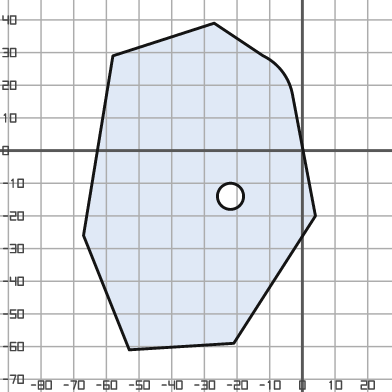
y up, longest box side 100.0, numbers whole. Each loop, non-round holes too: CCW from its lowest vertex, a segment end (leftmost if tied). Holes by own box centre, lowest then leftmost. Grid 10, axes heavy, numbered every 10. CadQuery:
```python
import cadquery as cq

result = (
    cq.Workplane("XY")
    .moveTo(-53.0, -61.0)
    .lineTo(-21.0, -59.0)
    .lineTo(4.0, -20.0)
    .lineTo(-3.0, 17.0)
    .threePointArc((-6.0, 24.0), (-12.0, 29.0))
    .lineTo(-27.0, 39.0)
    .lineTo(-58.0, 29.0)
    .lineTo(-67.0, -26.0)
    .close()
    .moveTo(-22.0, -14.0)
    .circle(4.0)
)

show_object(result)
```